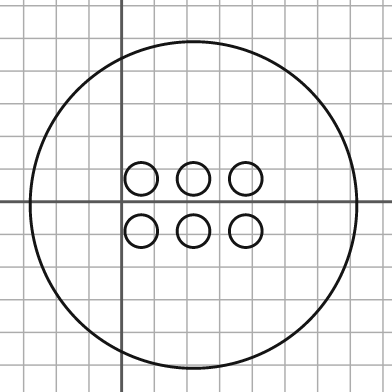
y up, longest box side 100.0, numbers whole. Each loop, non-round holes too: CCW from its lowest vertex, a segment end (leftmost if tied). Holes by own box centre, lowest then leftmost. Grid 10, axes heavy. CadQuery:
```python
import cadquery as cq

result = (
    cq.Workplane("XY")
    .moveTo(22.0, -1.0)
    .circle(50.0)
    .moveTo(6.0, -9.0)
    .circle(5.0)
    .moveTo(22.0, -9.0)
    .circle(5.0)
    .moveTo(38.0, -9.0)
    .circle(5.0)
    .moveTo(6.0, 7.0)
    .circle(5.0)
    .moveTo(22.0, 7.0)
    .circle(5.0)
    .moveTo(38.0, 7.0)
    .circle(5.0)
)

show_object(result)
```